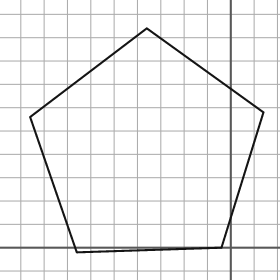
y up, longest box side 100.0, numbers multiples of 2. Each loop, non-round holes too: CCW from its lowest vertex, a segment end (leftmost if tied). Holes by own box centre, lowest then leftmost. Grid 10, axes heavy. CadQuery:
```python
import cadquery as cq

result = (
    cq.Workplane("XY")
    .moveTo(-66.0, -2.0)
    .lineTo(-4.0, 0.0)
    .lineTo(14.0, 58.0)
    .lineTo(-36.0, 94.0)
    .lineTo(-86.0, 56.0)
    .close()
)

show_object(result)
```